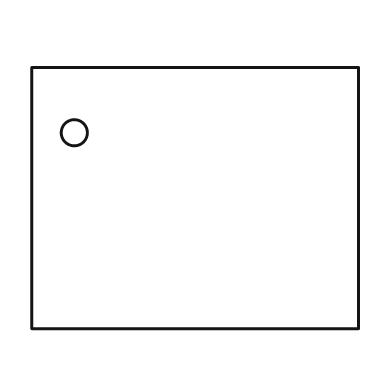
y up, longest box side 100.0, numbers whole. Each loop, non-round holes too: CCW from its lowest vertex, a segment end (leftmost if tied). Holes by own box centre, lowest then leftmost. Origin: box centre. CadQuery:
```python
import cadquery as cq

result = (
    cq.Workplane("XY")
    .moveTo(-50.0, -40.0)
    .lineTo(50.0, -40.0)
    .lineTo(50.0, 40.0)
    .lineTo(-50.0, 40.0)
    .close()
    .moveTo(-37.0, 20.0)
    .circle(4.0)
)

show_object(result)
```